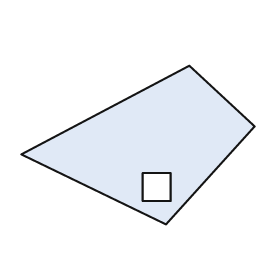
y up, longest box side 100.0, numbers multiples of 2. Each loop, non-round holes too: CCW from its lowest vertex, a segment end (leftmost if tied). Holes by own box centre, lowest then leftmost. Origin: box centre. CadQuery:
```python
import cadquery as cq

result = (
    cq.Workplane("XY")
    .moveTo(12.0, -34.0)
    .lineTo(50.0, 8.0)
    .lineTo(22.0, 34.0)
    .lineTo(-50.0, -4.0)
    .close()
    .moveTo(2.0, -24.0)
    .lineTo(14.0, -24.0)
    .lineTo(14.0, -12.0)
    .lineTo(2.0, -12.0)
    .close()
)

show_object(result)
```